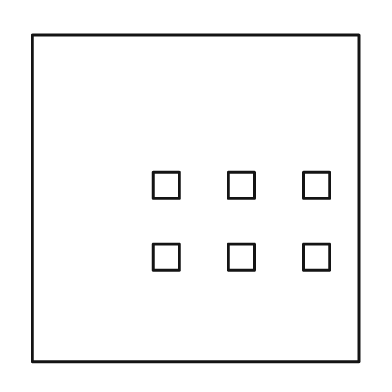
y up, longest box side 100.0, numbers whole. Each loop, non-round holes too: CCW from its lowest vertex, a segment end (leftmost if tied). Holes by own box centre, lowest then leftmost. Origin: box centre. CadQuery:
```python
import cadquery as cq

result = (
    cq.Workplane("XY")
    .moveTo(-50.0, -50.0)
    .lineTo(50.0, -50.0)
    .lineTo(50.0, 50.0)
    .lineTo(-50.0, 50.0)
    .close()
    .moveTo(-13.0, -22.0)
    .lineTo(-5.0, -22.0)
    .lineTo(-5.0, -14.0)
    .lineTo(-13.0, -14.0)
    .close()
    .moveTo(10.0, -22.0)
    .lineTo(18.0, -22.0)
    .lineTo(18.0, -14.0)
    .lineTo(10.0, -14.0)
    .close()
    .moveTo(33.0, -22.0)
    .lineTo(41.0, -22.0)
    .lineTo(41.0, -14.0)
    .lineTo(33.0, -14.0)
    .close()
    .moveTo(-13.0, 0.0)
    .lineTo(-5.0, 0.0)
    .lineTo(-5.0, 8.0)
    .lineTo(-13.0, 8.0)
    .close()
    .moveTo(10.0, 0.0)
    .lineTo(18.0, 0.0)
    .lineTo(18.0, 8.0)
    .lineTo(10.0, 8.0)
    .close()
    .moveTo(33.0, 0.0)
    .lineTo(41.0, 0.0)
    .lineTo(41.0, 8.0)
    .lineTo(33.0, 8.0)
    .close()
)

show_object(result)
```